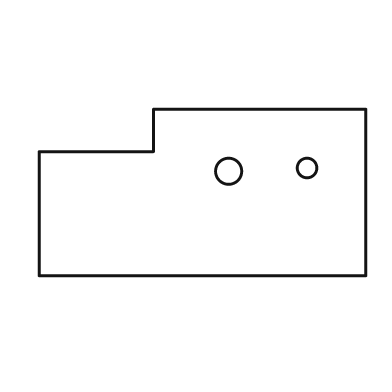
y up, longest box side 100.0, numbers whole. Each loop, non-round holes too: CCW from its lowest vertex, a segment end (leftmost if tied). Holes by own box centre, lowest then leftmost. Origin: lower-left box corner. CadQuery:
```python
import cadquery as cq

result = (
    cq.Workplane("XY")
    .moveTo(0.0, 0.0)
    .lineTo(100.0, 0.0)
    .lineTo(100.0, 51.0)
    .lineTo(35.0, 51.0)
    .lineTo(35.0, 38.0)
    .lineTo(0.0, 38.0)
    .close()
    .moveTo(58.0, 32.0)
    .circle(4.0)
    .moveTo(82.0, 33.0)
    .circle(3.0)
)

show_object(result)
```